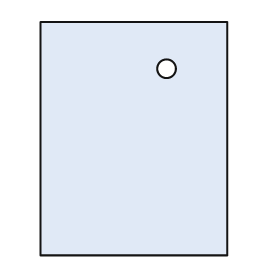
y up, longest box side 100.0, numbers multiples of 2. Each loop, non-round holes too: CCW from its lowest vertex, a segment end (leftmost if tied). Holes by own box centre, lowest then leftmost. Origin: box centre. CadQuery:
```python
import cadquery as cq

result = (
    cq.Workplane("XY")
    .moveTo(-40.0, -50.0)
    .lineTo(40.0, -50.0)
    .lineTo(40.0, 50.0)
    .lineTo(-40.0, 50.0)
    .close()
    .moveTo(14.0, 30.0)
    .circle(4.0)
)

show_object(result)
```